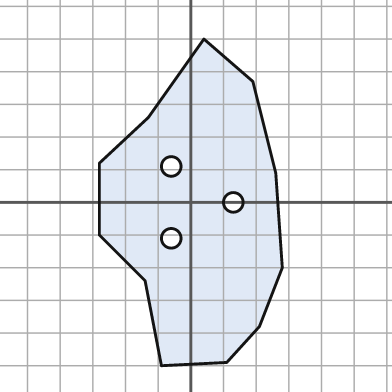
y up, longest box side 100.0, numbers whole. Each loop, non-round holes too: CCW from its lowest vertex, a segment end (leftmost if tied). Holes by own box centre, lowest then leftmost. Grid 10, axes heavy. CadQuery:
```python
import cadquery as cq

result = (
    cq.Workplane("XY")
    .moveTo(-9.0, -50.0)
    .lineTo(11.0, -49.0)
    .lineTo(21.0, -38.0)
    .lineTo(28.0, -20.0)
    .lineTo(26.0, 9.0)
    .lineTo(19.0, 37.0)
    .lineTo(4.0, 50.0)
    .lineTo(-13.0, 26.0)
    .lineTo(-28.0, 12.0)
    .lineTo(-28.0, -10.0)
    .lineTo(-14.0, -24.0)
    .close()
    .moveTo(-6.0, -11.0)
    .circle(3.0)
    .moveTo(13.0, 0.0)
    .circle(3.0)
    .moveTo(-6.0, 11.0)
    .circle(3.0)
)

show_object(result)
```